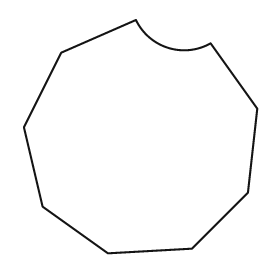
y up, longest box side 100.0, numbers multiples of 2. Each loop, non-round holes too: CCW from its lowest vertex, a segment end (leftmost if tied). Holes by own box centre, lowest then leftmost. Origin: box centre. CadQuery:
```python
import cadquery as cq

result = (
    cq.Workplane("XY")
    .moveTo(-14.0, -50.0)
    .lineTo(22.0, -48.0)
    .lineTo(46.0, -24.0)
    .lineTo(50.0, 12.0)
    .lineTo(30.0, 40.0)
    .threePointArc((12.0, 38.0), (-2.0, 50.0))
    .lineTo(-34.0, 36.0)
    .lineTo(-50.0, 4.0)
    .lineTo(-42.0, -30.0)
    .close()
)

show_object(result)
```